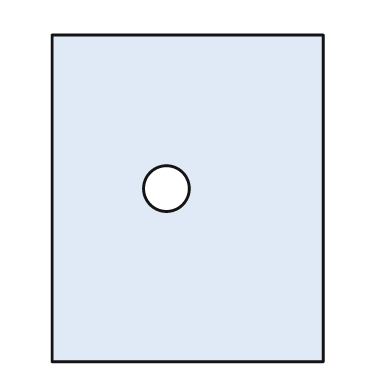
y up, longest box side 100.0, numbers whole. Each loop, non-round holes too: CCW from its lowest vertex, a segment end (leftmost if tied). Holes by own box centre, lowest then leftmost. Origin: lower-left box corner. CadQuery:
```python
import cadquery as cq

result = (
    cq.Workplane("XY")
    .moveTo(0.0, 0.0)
    .lineTo(83.0, 0.0)
    .lineTo(83.0, 100.0)
    .lineTo(0.0, 100.0)
    .close()
    .moveTo(35.0, 53.0)
    .circle(7.0)
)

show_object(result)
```